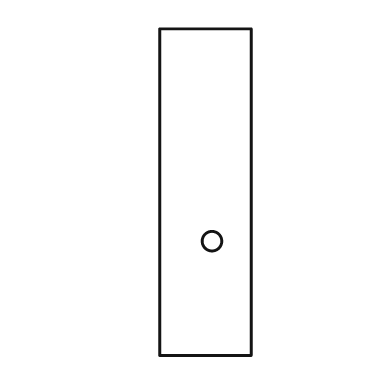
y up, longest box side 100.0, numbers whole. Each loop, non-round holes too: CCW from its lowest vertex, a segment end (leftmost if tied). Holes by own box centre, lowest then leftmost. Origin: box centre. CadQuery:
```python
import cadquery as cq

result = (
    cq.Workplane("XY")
    .moveTo(-14.0, -50.0)
    .lineTo(14.0, -50.0)
    .lineTo(14.0, 50.0)
    .lineTo(-14.0, 50.0)
    .close()
    .moveTo(2.0, -15.0)
    .circle(3.0)
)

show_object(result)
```